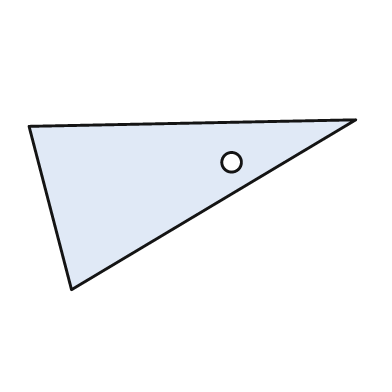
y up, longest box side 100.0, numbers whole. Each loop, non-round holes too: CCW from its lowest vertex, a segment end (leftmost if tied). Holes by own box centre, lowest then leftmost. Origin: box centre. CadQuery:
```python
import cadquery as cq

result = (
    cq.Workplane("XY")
    .moveTo(-37.0, -26.0)
    .lineTo(50.0, 26.0)
    .lineTo(-50.0, 24.0)
    .close()
    .moveTo(12.0, 13.0)
    .circle(3.0)
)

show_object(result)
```